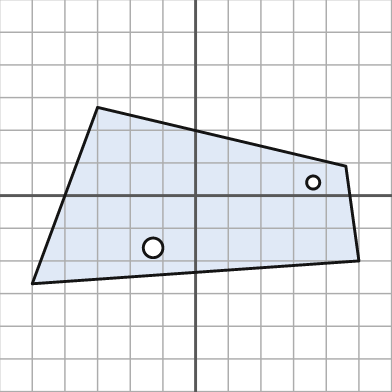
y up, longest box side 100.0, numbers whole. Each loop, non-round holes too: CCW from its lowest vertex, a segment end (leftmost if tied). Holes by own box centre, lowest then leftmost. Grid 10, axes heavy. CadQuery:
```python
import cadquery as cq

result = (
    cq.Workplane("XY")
    .moveTo(-50.0, -27.0)
    .lineTo(50.0, -20.0)
    .lineTo(46.0, 9.0)
    .lineTo(-30.0, 27.0)
    .close()
    .moveTo(-13.0, -16.0)
    .circle(3.0)
    .moveTo(36.0, 4.0)
    .circle(2.0)
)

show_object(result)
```